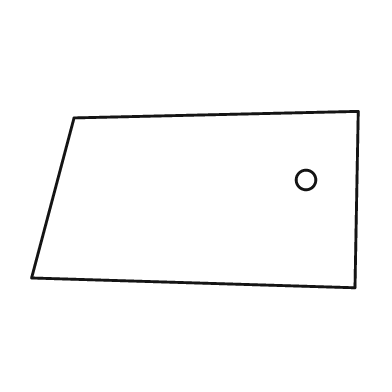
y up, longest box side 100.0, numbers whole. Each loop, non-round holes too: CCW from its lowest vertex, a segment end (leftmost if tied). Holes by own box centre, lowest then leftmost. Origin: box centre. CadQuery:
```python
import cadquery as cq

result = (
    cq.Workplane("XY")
    .moveTo(49.0, -27.0)
    .lineTo(50.0, 27.0)
    .lineTo(-37.0, 25.0)
    .lineTo(-50.0, -24.0)
    .close()
    .moveTo(34.0, 6.0)
    .circle(3.0)
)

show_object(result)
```